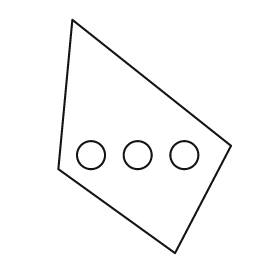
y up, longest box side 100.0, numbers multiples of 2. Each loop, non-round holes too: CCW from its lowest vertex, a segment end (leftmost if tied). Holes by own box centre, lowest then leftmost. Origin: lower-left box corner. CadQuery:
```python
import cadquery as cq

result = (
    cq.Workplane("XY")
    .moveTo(50.0, 0.0)
    .lineTo(74.0, 46.0)
    .lineTo(6.0, 100.0)
    .lineTo(0.0, 36.0)
    .close()
    .moveTo(14.0, 42.0)
    .circle(6.0)
    .moveTo(34.0, 42.0)
    .circle(6.0)
    .moveTo(54.0, 42.0)
    .circle(6.0)
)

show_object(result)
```